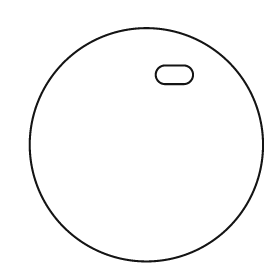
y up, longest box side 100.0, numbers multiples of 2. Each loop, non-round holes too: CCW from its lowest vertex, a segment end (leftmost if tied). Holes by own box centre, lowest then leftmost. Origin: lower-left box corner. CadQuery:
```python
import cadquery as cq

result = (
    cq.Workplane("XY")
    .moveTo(50.0, 50.0)
    .circle(50.0)
    .moveTo(58.0, 76.0)
    .lineTo(66.0, 76.0)
    .threePointArc((70.0, 80.0), (66.0, 84.0))
    .lineTo(58.0, 84.0)
    .threePointArc((54.0, 80.0), (58.0, 76.0))
    .close()
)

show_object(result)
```